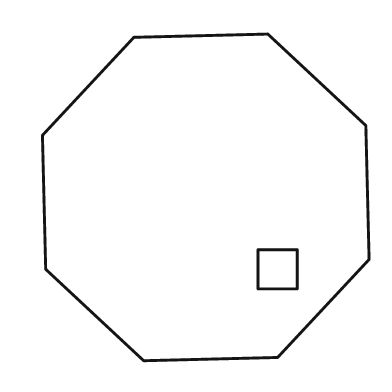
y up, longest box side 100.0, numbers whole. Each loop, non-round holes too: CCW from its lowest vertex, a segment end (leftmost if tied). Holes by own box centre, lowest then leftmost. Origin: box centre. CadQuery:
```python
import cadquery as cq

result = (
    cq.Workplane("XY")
    .moveTo(-19.0, -50.0)
    .lineTo(22.0, -49.0)
    .lineTo(50.0, -19.0)
    .lineTo(49.0, 22.0)
    .lineTo(19.0, 50.0)
    .lineTo(-22.0, 49.0)
    .lineTo(-50.0, 19.0)
    .lineTo(-49.0, -22.0)
    .close()
    .moveTo(16.0, -28.0)
    .lineTo(28.0, -28.0)
    .lineTo(28.0, -16.0)
    .lineTo(16.0, -16.0)
    .close()
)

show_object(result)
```